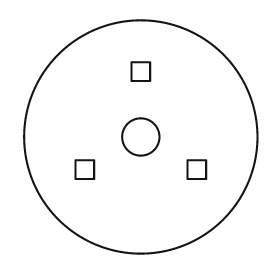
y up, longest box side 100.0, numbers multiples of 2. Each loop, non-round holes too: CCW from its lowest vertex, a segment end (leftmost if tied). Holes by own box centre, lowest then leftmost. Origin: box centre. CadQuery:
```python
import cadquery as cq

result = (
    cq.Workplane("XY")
    .moveTo(0.0, 0.0)
    .circle(50.0)
    .moveTo(-28.0, -18.0)
    .lineTo(-20.0, -18.0)
    .lineTo(-20.0, -10.0)
    .lineTo(-28.0, -10.0)
    .close()
    .moveTo(20.0, -18.0)
    .lineTo(28.0, -18.0)
    .lineTo(28.0, -10.0)
    .lineTo(20.0, -10.0)
    .close()
    .moveTo(0.0, 0.0)
    .circle(8.0)
    .moveTo(-4.0, 24.0)
    .lineTo(4.0, 24.0)
    .lineTo(4.0, 32.0)
    .lineTo(-4.0, 32.0)
    .close()
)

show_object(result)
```